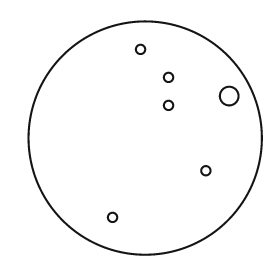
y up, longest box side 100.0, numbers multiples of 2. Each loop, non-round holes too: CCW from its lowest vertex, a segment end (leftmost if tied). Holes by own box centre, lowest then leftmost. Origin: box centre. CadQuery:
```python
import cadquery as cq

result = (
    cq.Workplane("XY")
    .moveTo(0.0, 0.0)
    .circle(50.0)
    .moveTo(-14.0, -34.0)
    .circle(2.0)
    .moveTo(26.0, -14.0)
    .circle(2.0)
    .moveTo(10.0, 14.0)
    .circle(2.0)
    .moveTo(36.0, 18.0)
    .circle(4.0)
    .moveTo(10.0, 26.0)
    .circle(2.0)
    .moveTo(-2.0, 38.0)
    .circle(2.0)
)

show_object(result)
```